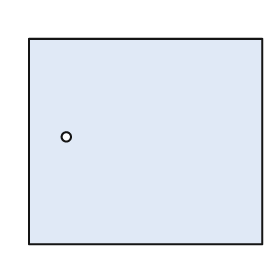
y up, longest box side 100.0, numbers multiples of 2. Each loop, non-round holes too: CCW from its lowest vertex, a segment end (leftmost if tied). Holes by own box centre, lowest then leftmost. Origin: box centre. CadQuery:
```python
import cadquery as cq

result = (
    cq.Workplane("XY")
    .moveTo(-50.0, -44.0)
    .lineTo(50.0, -44.0)
    .lineTo(50.0, 44.0)
    .lineTo(-50.0, 44.0)
    .close()
    .moveTo(-34.0, 2.0)
    .circle(2.0)
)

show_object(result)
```